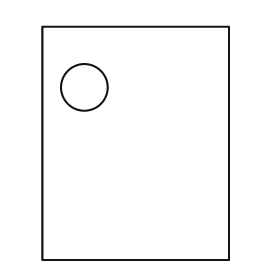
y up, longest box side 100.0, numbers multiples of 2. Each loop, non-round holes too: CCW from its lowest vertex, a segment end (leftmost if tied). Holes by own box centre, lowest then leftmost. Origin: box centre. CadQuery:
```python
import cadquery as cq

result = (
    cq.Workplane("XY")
    .moveTo(-40.0, -50.0)
    .lineTo(40.0, -50.0)
    .lineTo(40.0, 50.0)
    .lineTo(-40.0, 50.0)
    .close()
    .moveTo(-22.0, 24.0)
    .circle(10.0)
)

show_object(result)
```